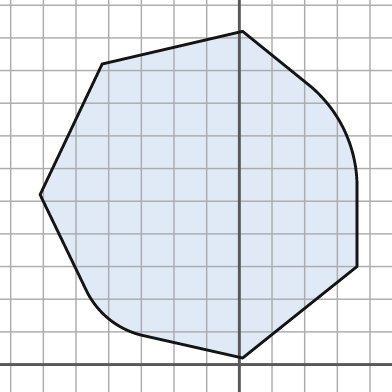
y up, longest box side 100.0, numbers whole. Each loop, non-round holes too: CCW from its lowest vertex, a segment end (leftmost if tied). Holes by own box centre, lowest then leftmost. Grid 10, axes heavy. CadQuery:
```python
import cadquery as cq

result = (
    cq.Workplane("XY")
    .moveTo(1.0, 2.0)
    .lineTo(36.0, 30.0)
    .lineTo(36.0, 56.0)
    .threePointArc((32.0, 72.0), (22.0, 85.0))
    .lineTo(1.0, 102.0)
    .lineTo(-42.0, 92.0)
    .lineTo(-61.0, 52.0)
    .lineTo(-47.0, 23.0)
    .threePointArc((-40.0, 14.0), (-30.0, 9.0))
    .close()
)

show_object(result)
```